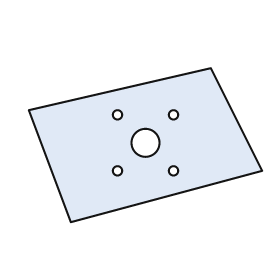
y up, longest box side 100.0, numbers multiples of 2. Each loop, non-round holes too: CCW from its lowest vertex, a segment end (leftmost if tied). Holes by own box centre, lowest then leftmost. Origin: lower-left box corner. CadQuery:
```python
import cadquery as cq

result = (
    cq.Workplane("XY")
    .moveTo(18.0, 0.0)
    .lineTo(100.0, 22.0)
    .lineTo(78.0, 66.0)
    .lineTo(0.0, 48.0)
    .close()
    .moveTo(38.0, 22.0)
    .circle(2.0)
    .moveTo(62.0, 22.0)
    .circle(2.0)
    .moveTo(50.0, 34.0)
    .circle(6.0)
    .moveTo(38.0, 46.0)
    .circle(2.0)
    .moveTo(62.0, 46.0)
    .circle(2.0)
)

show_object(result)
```